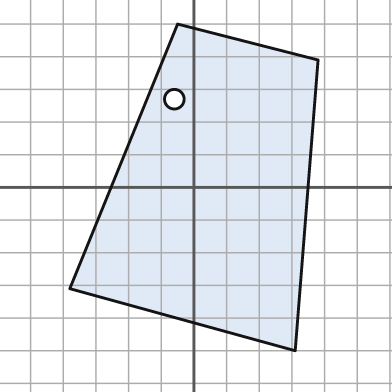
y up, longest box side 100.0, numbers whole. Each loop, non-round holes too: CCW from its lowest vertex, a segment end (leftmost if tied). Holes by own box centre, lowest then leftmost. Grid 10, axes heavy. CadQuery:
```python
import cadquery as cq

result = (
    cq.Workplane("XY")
    .moveTo(31.0, -50.0)
    .lineTo(38.0, 39.0)
    .lineTo(-5.0, 50.0)
    .lineTo(-38.0, -31.0)
    .close()
    .moveTo(-6.0, 27.0)
    .circle(3.0)
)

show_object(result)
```